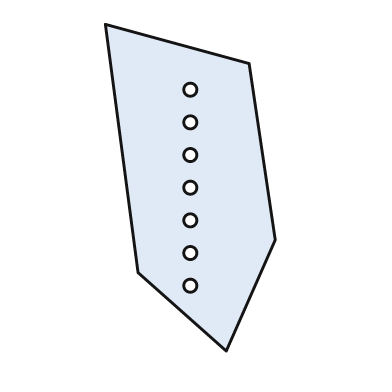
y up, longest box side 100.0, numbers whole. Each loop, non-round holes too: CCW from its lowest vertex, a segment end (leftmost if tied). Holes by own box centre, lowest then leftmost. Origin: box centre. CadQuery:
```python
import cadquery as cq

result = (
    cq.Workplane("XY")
    .moveTo(11.0, -50.0)
    .lineTo(26.0, -16.0)
    .lineTo(18.0, 38.0)
    .lineTo(-26.0, 50.0)
    .lineTo(-16.0, -26.0)
    .close()
    .moveTo(0.0, -30.0)
    .circle(2.0)
    .moveTo(0.0, -20.0)
    .circle(2.0)
    .moveTo(0.0, -10.0)
    .circle(2.0)
    .moveTo(0.0, 0.0)
    .circle(2.0)
    .moveTo(0.0, 10.0)
    .circle(2.0)
    .moveTo(0.0, 20.0)
    .circle(2.0)
    .moveTo(0.0, 30.0)
    .circle(2.0)
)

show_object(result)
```